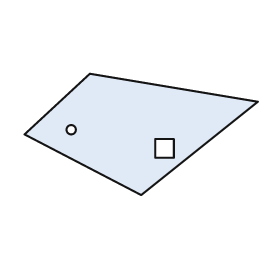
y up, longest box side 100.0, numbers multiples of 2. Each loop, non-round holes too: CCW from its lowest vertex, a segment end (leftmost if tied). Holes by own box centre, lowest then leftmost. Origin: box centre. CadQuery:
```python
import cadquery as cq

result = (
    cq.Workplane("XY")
    .moveTo(0.0, -26.0)
    .lineTo(50.0, 14.0)
    .lineTo(-22.0, 26.0)
    .lineTo(-50.0, 0.0)
    .close()
    .moveTo(6.0, -10.0)
    .lineTo(14.0, -10.0)
    .lineTo(14.0, -2.0)
    .lineTo(6.0, -2.0)
    .close()
    .moveTo(-30.0, 2.0)
    .circle(2.0)
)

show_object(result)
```